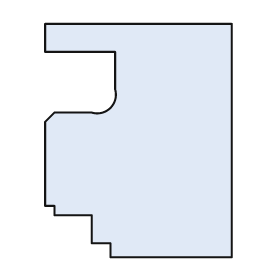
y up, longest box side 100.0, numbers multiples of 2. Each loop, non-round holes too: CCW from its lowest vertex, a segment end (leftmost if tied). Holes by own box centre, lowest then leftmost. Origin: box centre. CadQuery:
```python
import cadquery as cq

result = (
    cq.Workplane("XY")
    .moveTo(-12.0, -50.0)
    .lineTo(40.0, -50.0)
    .lineTo(40.0, 50.0)
    .lineTo(-40.0, 50.0)
    .lineTo(-40.0, 38.0)
    .lineTo(-10.0, 38.0)
    .lineTo(-10.0, 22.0)
    .threePointArc((-12.0, 14.0), (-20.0, 12.0))
    .lineTo(-36.0, 12.0)
    .lineTo(-40.0, 8.0)
    .lineTo(-40.0, -28.0)
    .lineTo(-36.0, -28.0)
    .lineTo(-36.0, -32.0)
    .lineTo(-20.0, -32.0)
    .lineTo(-20.0, -44.0)
    .lineTo(-12.0, -44.0)
    .close()
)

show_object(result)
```